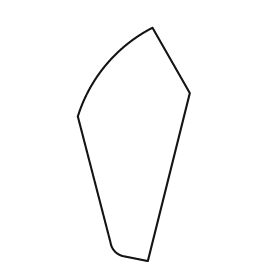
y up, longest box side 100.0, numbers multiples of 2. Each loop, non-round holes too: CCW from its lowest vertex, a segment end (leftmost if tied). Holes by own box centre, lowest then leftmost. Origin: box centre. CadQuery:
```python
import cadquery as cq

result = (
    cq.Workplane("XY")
    .moveTo(6.0, -50.0)
    .lineTo(24.0, 22.0)
    .lineTo(8.0, 50.0)
    .threePointArc((-12.0, 34.0), (-24.0, 12.0))
    .lineTo(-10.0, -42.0)
    .threePointArc((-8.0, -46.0), (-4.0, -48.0))
    .close()
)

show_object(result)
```